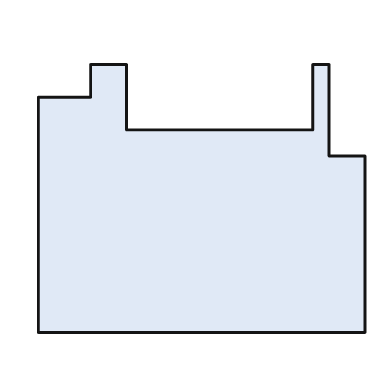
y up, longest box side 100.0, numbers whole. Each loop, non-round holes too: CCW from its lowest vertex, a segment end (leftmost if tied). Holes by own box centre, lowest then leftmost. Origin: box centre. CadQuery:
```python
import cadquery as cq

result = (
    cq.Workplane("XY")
    .moveTo(-50.0, -41.0)
    .lineTo(50.0, -41.0)
    .lineTo(50.0, 13.0)
    .lineTo(39.0, 13.0)
    .lineTo(39.0, 41.0)
    .lineTo(34.0, 41.0)
    .lineTo(34.0, 21.0)
    .lineTo(-23.0, 21.0)
    .lineTo(-23.0, 41.0)
    .lineTo(-34.0, 41.0)
    .lineTo(-34.0, 31.0)
    .lineTo(-50.0, 31.0)
    .close()
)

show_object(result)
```